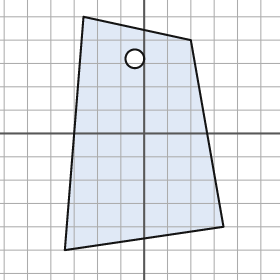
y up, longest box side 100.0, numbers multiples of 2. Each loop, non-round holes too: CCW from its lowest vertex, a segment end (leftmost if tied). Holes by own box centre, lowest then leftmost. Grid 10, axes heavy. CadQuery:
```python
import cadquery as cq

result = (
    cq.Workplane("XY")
    .moveTo(-34.0, -50.0)
    .lineTo(34.0, -40.0)
    .lineTo(20.0, 40.0)
    .lineTo(-26.0, 50.0)
    .close()
    .moveTo(-4.0, 32.0)
    .circle(4.0)
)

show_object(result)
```